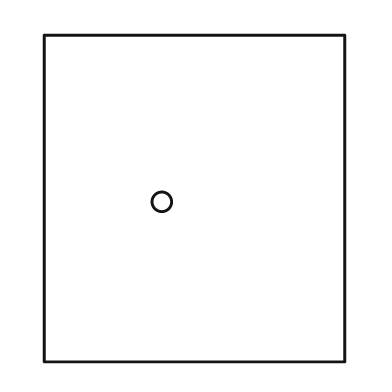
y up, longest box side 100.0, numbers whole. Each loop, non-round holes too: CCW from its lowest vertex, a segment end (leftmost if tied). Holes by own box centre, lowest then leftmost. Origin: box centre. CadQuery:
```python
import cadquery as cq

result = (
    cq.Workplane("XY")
    .moveTo(-46.0, -50.0)
    .lineTo(46.0, -50.0)
    .lineTo(46.0, 50.0)
    .lineTo(-46.0, 50.0)
    .close()
    .moveTo(-10.0, -1.0)
    .circle(3.0)
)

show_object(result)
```